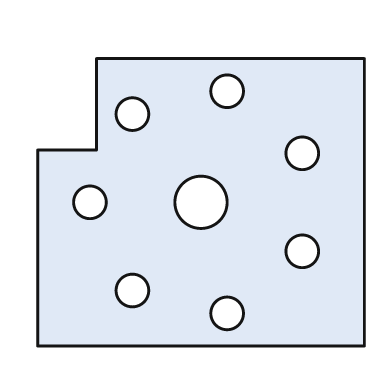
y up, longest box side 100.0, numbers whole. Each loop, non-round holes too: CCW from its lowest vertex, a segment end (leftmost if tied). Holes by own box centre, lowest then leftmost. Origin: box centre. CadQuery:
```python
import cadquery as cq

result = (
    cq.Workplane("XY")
    .moveTo(-50.0, -44.0)
    .lineTo(50.0, -44.0)
    .lineTo(50.0, 44.0)
    .lineTo(-32.0, 44.0)
    .lineTo(-32.0, 16.0)
    .lineTo(-50.0, 16.0)
    .close()
    .moveTo(8.0, -34.0)
    .circle(5.0)
    .moveTo(-21.0, -27.0)
    .circle(5.0)
    .moveTo(31.0, -15.0)
    .circle(5.0)
    .moveTo(-34.0, 0.0)
    .circle(5.0)
    .moveTo(0.0, 0.0)
    .circle(8.0)
    .moveTo(31.0, 15.0)
    .circle(5.0)
    .moveTo(-21.0, 27.0)
    .circle(5.0)
    .moveTo(8.0, 34.0)
    .circle(5.0)
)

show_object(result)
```